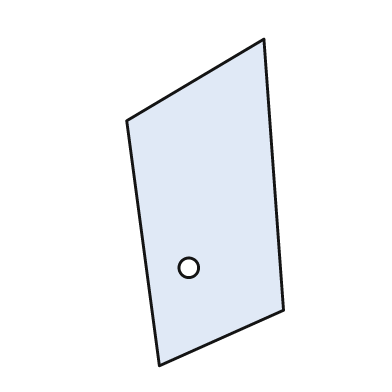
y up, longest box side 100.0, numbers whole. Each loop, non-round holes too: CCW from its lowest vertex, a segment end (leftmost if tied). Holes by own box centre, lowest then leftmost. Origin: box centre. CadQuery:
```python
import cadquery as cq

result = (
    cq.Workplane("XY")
    .moveTo(-14.0, -50.0)
    .lineTo(24.0, -33.0)
    .lineTo(18.0, 50.0)
    .lineTo(-24.0, 25.0)
    .close()
    .moveTo(-5.0, -20.0)
    .circle(3.0)
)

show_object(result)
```